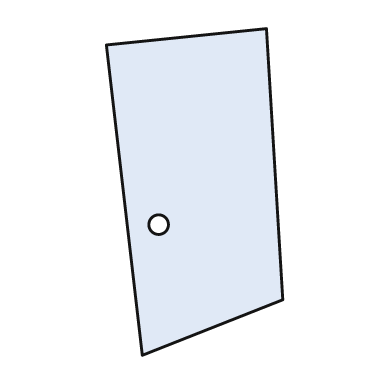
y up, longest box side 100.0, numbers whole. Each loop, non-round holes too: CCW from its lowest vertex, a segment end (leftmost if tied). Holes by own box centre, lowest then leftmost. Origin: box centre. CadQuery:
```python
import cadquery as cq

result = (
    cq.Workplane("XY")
    .moveTo(-16.0, -50.0)
    .lineTo(27.0, -33.0)
    .lineTo(22.0, 50.0)
    .lineTo(-27.0, 45.0)
    .close()
    .moveTo(-11.0, -10.0)
    .circle(3.0)
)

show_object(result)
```